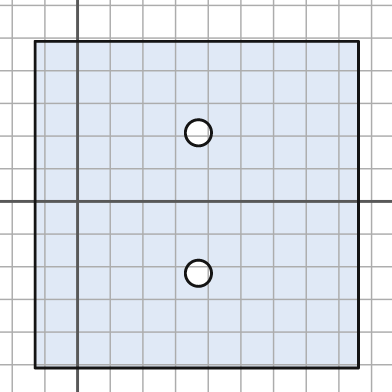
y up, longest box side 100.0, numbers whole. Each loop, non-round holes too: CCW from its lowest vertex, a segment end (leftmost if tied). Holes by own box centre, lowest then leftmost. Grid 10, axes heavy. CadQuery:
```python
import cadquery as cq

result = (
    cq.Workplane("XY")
    .moveTo(-13.0, -51.0)
    .lineTo(86.0, -51.0)
    .lineTo(86.0, 49.0)
    .lineTo(-13.0, 49.0)
    .close()
    .moveTo(37.0, -22.0)
    .circle(4.0)
    .moveTo(37.0, 21.0)
    .circle(4.0)
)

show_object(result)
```